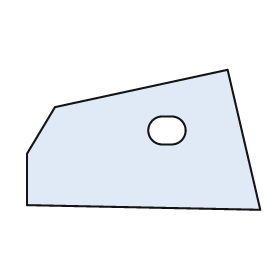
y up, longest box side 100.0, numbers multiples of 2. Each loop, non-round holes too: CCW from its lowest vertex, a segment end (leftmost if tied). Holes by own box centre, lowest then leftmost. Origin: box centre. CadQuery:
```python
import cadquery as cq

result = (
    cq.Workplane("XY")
    .moveTo(50.0, -30.0)
    .lineTo(36.0, 30.0)
    .lineTo(-38.0, 14.0)
    .lineTo(-50.0, -6.0)
    .lineTo(-50.0, -28.0)
    .close()
    .moveTo(8.0, -2.0)
    .lineTo(12.0, -2.0)
    .threePointArc((18.0, 4.0), (12.0, 10.0))
    .lineTo(8.0, 10.0)
    .threePointArc((2.0, 4.0), (8.0, -2.0))
    .close()
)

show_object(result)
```